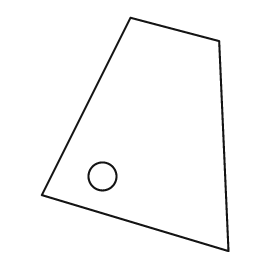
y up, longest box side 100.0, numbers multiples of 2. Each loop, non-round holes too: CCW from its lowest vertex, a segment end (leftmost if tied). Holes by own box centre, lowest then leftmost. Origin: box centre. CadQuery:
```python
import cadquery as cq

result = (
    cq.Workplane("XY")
    .moveTo(40.0, -50.0)
    .lineTo(36.0, 40.0)
    .lineTo(-2.0, 50.0)
    .lineTo(-40.0, -26.0)
    .close()
    .moveTo(-14.0, -18.0)
    .circle(6.0)
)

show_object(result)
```